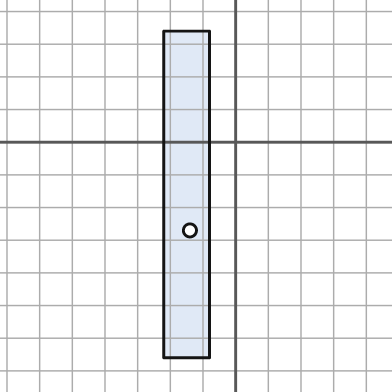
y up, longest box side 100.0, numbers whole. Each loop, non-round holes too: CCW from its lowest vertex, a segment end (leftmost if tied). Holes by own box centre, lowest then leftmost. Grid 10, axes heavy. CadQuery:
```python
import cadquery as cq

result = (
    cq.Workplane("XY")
    .moveTo(-22.0, -66.0)
    .lineTo(-8.0, -66.0)
    .lineTo(-8.0, 34.0)
    .lineTo(-22.0, 34.0)
    .close()
    .moveTo(-14.0, -27.0)
    .circle(2.0)
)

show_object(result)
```